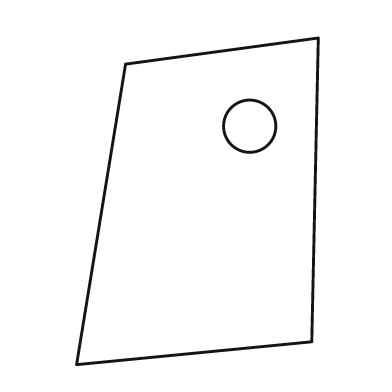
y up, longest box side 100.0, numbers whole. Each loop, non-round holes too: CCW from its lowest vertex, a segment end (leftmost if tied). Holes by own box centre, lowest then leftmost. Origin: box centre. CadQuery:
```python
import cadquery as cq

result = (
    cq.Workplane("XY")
    .moveTo(-37.0, -50.0)
    .lineTo(35.0, -43.0)
    .lineTo(37.0, 50.0)
    .lineTo(-22.0, 42.0)
    .close()
    .moveTo(16.0, 23.0)
    .circle(8.0)
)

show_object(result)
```